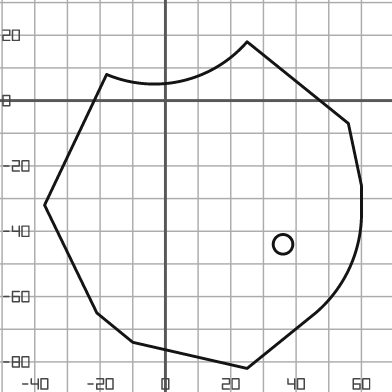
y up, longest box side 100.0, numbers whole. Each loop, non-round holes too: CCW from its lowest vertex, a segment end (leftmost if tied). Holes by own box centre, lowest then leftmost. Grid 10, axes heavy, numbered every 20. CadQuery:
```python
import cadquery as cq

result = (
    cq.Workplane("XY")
    .moveTo(25.0, -82.0)
    .lineTo(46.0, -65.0)
    .threePointArc((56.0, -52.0), (60.0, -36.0))
    .lineTo(60.0, -26.0)
    .lineTo(56.0, -7.0)
    .lineTo(25.0, 18.0)
    .threePointArc((5.0, 6.0), (-18.0, 8.0))
    .lineTo(-37.0, -32.0)
    .lineTo(-21.0, -65.0)
    .lineTo(-10.0, -74.0)
    .close()
    .moveTo(36.0, -44.0)
    .circle(3.0)
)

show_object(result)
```